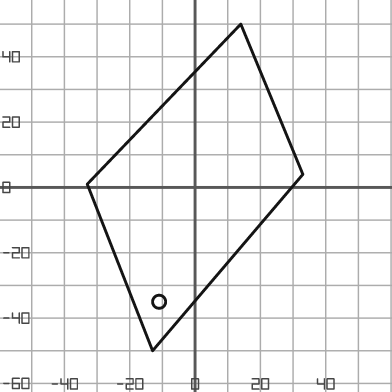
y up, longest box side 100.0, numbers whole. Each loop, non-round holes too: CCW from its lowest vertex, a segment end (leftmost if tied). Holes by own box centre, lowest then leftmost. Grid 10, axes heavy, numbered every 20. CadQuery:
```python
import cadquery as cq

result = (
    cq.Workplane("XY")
    .moveTo(-13.0, -50.0)
    .lineTo(33.0, 4.0)
    .lineTo(14.0, 50.0)
    .lineTo(-33.0, 1.0)
    .close()
    .moveTo(-11.0, -35.0)
    .circle(2.0)
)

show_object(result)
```